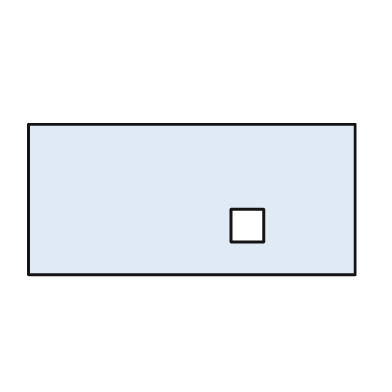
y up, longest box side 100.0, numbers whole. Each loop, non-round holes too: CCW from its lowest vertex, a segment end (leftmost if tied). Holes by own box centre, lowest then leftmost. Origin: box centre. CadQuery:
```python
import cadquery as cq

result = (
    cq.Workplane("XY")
    .moveTo(-50.0, -23.0)
    .lineTo(50.0, -23.0)
    .lineTo(50.0, 23.0)
    .lineTo(-50.0, 23.0)
    .close()
    .moveTo(12.0, -13.0)
    .lineTo(22.0, -13.0)
    .lineTo(22.0, -3.0)
    .lineTo(12.0, -3.0)
    .close()
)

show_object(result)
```